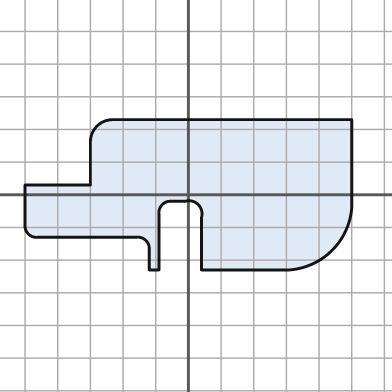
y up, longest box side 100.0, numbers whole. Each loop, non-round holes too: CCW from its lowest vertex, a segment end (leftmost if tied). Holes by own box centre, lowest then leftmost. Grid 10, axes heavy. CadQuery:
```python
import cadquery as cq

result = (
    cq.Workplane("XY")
    .moveTo(-12.0, -23.0)
    .lineTo(-9.0, -23.0)
    .lineTo(-9.0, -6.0)
    .threePointArc((-8.0, -3.0), (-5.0, -2.0))
    .lineTo(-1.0, -2.0)
    .threePointArc((3.0, -3.0), (4.0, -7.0))
    .lineTo(4.0, -23.0)
    .lineTo(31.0, -23.0)
    .threePointArc((44.0, -17.0), (50.0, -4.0))
    .lineTo(50.0, 23.0)
    .lineTo(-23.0, 23.0)
    .threePointArc((-28.0, 21.0), (-30.0, 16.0))
    .lineTo(-30.0, 3.0)
    .lineTo(-50.0, 3.0)
    .lineTo(-50.0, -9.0)
    .threePointArc((-49.0, -12.0), (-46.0, -13.0))
    .lineTo(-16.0, -13.0)
    .threePointArc((-13.0, -14.0), (-12.0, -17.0))
    .close()
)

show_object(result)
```